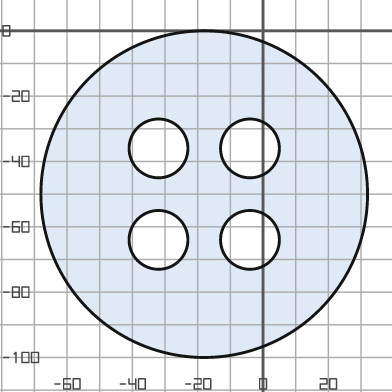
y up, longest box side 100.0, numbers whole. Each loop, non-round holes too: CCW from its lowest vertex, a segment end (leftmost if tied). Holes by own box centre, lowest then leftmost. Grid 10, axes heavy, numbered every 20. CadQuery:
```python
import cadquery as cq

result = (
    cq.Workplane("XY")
    .moveTo(-18.0, -50.0)
    .circle(50.0)
    .moveTo(-32.0, -64.0)
    .circle(9.0)
    .moveTo(-4.0, -64.0)
    .circle(9.0)
    .moveTo(-32.0, -36.0)
    .circle(9.0)
    .moveTo(-4.0, -36.0)
    .circle(9.0)
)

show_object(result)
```